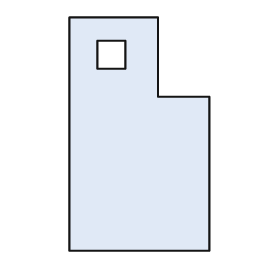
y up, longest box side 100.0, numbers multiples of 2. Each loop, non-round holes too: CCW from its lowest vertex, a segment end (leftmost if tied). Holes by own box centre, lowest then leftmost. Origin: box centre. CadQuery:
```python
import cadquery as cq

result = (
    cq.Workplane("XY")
    .moveTo(-30.0, -50.0)
    .lineTo(30.0, -50.0)
    .lineTo(30.0, 16.0)
    .lineTo(8.0, 16.0)
    .lineTo(8.0, 50.0)
    .lineTo(-30.0, 50.0)
    .close()
    .moveTo(-18.0, 28.0)
    .lineTo(-6.0, 28.0)
    .lineTo(-6.0, 40.0)
    .lineTo(-18.0, 40.0)
    .close()
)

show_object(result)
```